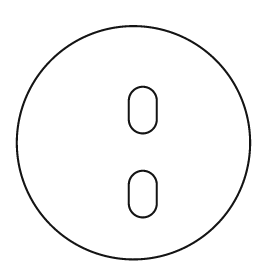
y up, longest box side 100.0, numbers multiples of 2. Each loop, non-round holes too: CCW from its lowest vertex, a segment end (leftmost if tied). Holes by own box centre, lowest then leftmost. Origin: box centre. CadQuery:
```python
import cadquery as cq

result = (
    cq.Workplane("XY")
    .moveTo(0.0, 0.0)
    .circle(50.0)
    .moveTo(-2.0, -26.0)
    .threePointArc((4.0, -32.0), (10.0, -26.0))
    .lineTo(10.0, -18.0)
    .threePointArc((4.0, -12.0), (-2.0, -18.0))
    .close()
    .moveTo(-2.0, 10.0)
    .threePointArc((4.0, 4.0), (10.0, 10.0))
    .lineTo(10.0, 18.0)
    .threePointArc((4.0, 24.0), (-2.0, 18.0))
    .close()
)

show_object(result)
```